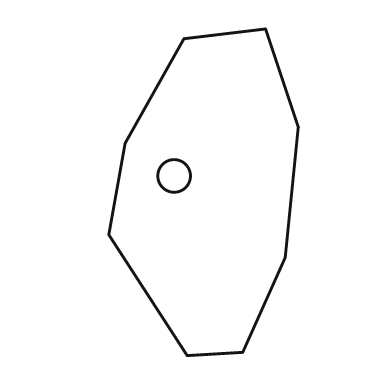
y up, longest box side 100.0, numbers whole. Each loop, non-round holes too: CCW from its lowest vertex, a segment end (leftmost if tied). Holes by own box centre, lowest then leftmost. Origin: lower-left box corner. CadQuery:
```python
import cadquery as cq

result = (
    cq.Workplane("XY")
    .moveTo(24.0, 0.0)
    .lineTo(41.0, 1.0)
    .lineTo(54.0, 30.0)
    .lineTo(58.0, 70.0)
    .lineTo(48.0, 100.0)
    .lineTo(23.0, 97.0)
    .lineTo(5.0, 65.0)
    .lineTo(0.0, 37.0)
    .close()
    .moveTo(20.0, 55.0)
    .circle(5.0)
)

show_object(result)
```